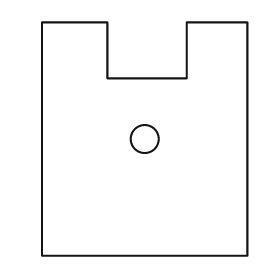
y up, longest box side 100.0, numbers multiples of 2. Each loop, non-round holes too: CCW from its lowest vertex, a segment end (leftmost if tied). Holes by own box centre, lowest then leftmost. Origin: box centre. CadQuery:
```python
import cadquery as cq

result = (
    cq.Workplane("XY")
    .moveTo(-44.0, -50.0)
    .lineTo(44.0, -50.0)
    .lineTo(44.0, 50.0)
    .lineTo(18.0, 50.0)
    .lineTo(18.0, 26.0)
    .lineTo(-16.0, 26.0)
    .lineTo(-16.0, 50.0)
    .lineTo(-44.0, 50.0)
    .close()
    .moveTo(0.0, 0.0)
    .circle(6.0)
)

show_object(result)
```